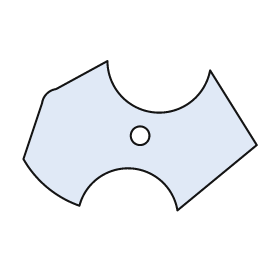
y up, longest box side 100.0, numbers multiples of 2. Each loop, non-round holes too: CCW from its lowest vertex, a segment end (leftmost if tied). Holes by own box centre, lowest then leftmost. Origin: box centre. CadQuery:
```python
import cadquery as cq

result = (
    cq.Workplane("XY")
    .moveTo(16.0, -32.0)
    .lineTo(50.0, -4.0)
    .lineTo(30.0, 28.0)
    .threePointArc((6.0, 10.0), (-14.0, 32.0))
    .lineTo(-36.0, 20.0)
    .threePointArc((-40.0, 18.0), (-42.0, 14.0))
    .lineTo(-50.0, -10.0)
    .threePointArc((-40.0, -22.0), (-26.0, -30.0))
    .threePointArc((-4.0, -14.0), (16.0, -32.0))
    .close()
    .moveTo(0.0, 0.0)
    .circle(4.0)
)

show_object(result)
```